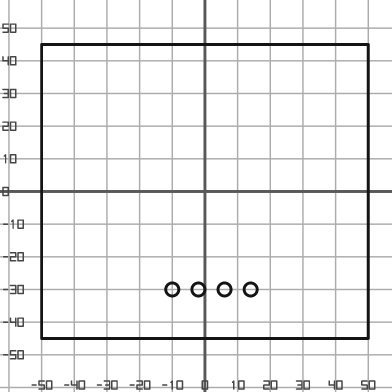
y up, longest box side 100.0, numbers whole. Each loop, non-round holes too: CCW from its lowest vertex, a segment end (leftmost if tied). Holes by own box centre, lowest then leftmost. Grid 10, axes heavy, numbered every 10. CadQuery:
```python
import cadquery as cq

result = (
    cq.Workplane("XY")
    .moveTo(-50.0, -45.0)
    .lineTo(50.0, -45.0)
    .lineTo(50.0, 45.0)
    .lineTo(-50.0, 45.0)
    .close()
    .moveTo(-10.0, -30.0)
    .circle(2.0)
    .moveTo(-2.0, -30.0)
    .circle(2.0)
    .moveTo(6.0, -30.0)
    .circle(2.0)
    .moveTo(14.0, -30.0)
    .circle(2.0)
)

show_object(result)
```